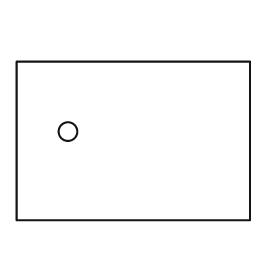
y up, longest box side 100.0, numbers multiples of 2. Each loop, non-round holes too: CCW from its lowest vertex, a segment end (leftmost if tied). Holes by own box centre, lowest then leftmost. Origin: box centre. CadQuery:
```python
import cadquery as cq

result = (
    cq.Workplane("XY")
    .moveTo(-50.0, -34.0)
    .lineTo(50.0, -34.0)
    .lineTo(50.0, 34.0)
    .lineTo(-50.0, 34.0)
    .close()
    .moveTo(-28.0, 4.0)
    .circle(4.0)
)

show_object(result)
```